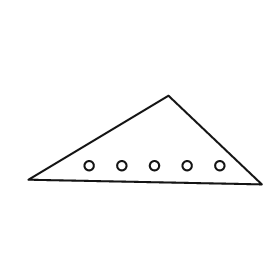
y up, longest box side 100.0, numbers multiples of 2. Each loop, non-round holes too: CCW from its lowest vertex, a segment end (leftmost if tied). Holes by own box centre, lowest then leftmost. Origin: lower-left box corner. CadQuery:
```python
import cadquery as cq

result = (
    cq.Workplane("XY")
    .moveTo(100.0, 0.0)
    .lineTo(60.0, 38.0)
    .lineTo(0.0, 2.0)
    .close()
    .moveTo(26.0, 8.0)
    .circle(2.0)
    .moveTo(40.0, 8.0)
    .circle(2.0)
    .moveTo(54.0, 8.0)
    .circle(2.0)
    .moveTo(68.0, 8.0)
    .circle(2.0)
    .moveTo(82.0, 8.0)
    .circle(2.0)
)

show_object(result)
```